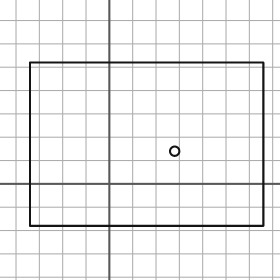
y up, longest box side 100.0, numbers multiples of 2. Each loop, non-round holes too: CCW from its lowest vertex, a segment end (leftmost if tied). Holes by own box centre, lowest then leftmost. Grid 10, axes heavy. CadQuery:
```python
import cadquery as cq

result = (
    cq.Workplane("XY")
    .moveTo(-34.0, -18.0)
    .lineTo(66.0, -18.0)
    .lineTo(66.0, 52.0)
    .lineTo(-34.0, 52.0)
    .close()
    .moveTo(28.0, 14.0)
    .circle(2.0)
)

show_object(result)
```